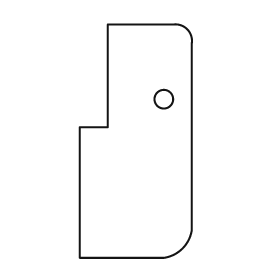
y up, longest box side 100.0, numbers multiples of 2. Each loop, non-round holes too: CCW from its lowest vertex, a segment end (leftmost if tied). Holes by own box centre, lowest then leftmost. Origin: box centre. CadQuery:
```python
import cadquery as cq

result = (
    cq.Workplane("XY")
    .moveTo(-24.0, -50.0)
    .lineTo(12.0, -50.0)
    .threePointArc((20.0, -46.0), (24.0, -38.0))
    .lineTo(24.0, 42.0)
    .threePointArc((22.0, 48.0), (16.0, 50.0))
    .lineTo(-12.0, 50.0)
    .lineTo(-12.0, 6.0)
    .lineTo(-24.0, 6.0)
    .close()
    .moveTo(12.0, 18.0)
    .circle(4.0)
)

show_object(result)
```